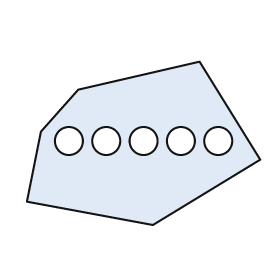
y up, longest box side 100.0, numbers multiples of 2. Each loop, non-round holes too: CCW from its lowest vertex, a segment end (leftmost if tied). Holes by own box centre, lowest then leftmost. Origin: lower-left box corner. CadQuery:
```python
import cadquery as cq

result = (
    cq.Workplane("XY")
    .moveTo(54.0, 0.0)
    .lineTo(100.0, 28.0)
    .lineTo(74.0, 70.0)
    .lineTo(22.0, 58.0)
    .lineTo(6.0, 40.0)
    .lineTo(0.0, 10.0)
    .close()
    .moveTo(18.0, 36.0)
    .circle(6.0)
    .moveTo(34.0, 36.0)
    .circle(6.0)
    .moveTo(50.0, 36.0)
    .circle(6.0)
    .moveTo(66.0, 36.0)
    .circle(6.0)
    .moveTo(82.0, 36.0)
    .circle(6.0)
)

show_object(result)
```